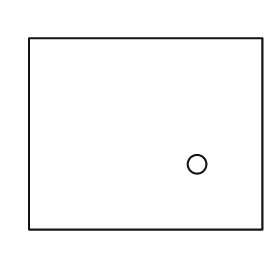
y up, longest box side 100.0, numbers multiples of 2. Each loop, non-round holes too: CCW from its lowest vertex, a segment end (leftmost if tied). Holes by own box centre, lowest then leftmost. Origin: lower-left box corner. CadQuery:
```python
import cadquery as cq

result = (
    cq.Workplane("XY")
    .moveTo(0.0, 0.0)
    .lineTo(100.0, 0.0)
    .lineTo(100.0, 82.0)
    .lineTo(0.0, 82.0)
    .close()
    .moveTo(72.0, 28.0)
    .circle(4.0)
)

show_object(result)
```